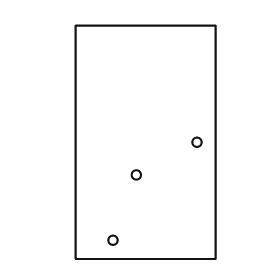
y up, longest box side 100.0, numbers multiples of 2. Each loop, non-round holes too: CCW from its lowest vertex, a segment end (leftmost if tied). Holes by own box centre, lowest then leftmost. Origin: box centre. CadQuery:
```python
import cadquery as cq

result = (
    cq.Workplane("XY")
    .moveTo(-30.0, -50.0)
    .lineTo(30.0, -50.0)
    .lineTo(30.0, 50.0)
    .lineTo(-30.0, 50.0)
    .close()
    .moveTo(-14.0, -42.0)
    .circle(2.0)
    .moveTo(-4.0, -14.0)
    .circle(2.0)
    .moveTo(22.0, 0.0)
    .circle(2.0)
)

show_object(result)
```